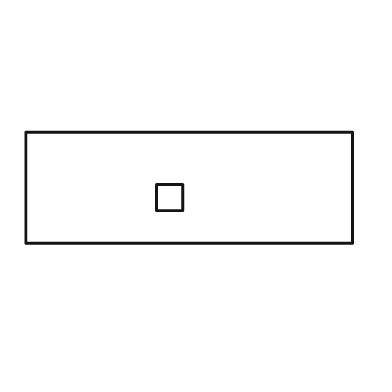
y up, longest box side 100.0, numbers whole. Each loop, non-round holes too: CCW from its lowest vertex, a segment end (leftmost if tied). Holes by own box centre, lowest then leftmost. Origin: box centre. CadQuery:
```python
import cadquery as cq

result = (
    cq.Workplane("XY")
    .moveTo(-50.0, -17.0)
    .lineTo(50.0, -17.0)
    .lineTo(50.0, 17.0)
    .lineTo(-50.0, 17.0)
    .close()
    .moveTo(-10.0, -7.0)
    .lineTo(-2.0, -7.0)
    .lineTo(-2.0, 1.0)
    .lineTo(-10.0, 1.0)
    .close()
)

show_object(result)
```